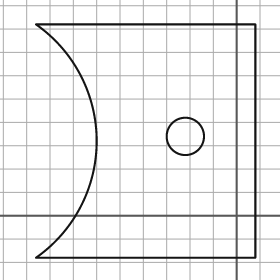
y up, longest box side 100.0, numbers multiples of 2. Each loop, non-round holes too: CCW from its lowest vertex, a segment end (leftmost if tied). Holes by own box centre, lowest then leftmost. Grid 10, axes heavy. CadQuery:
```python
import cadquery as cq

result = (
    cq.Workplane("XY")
    .moveTo(-86.0, -18.0)
    .lineTo(8.0, -18.0)
    .lineTo(8.0, 82.0)
    .lineTo(-86.0, 82.0)
    .threePointArc((-60.0, 32.0), (-86.0, -18.0))
    .close()
    .moveTo(-22.0, 34.0)
    .circle(8.0)
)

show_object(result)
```